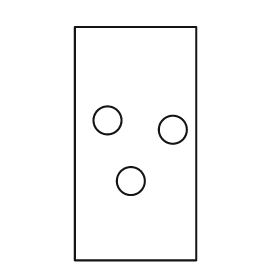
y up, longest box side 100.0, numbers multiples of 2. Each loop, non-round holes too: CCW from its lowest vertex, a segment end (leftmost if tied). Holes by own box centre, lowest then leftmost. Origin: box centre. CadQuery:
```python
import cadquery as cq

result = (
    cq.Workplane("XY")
    .moveTo(-26.0, -50.0)
    .lineTo(26.0, -50.0)
    .lineTo(26.0, 50.0)
    .lineTo(-26.0, 50.0)
    .close()
    .moveTo(-2.0, -16.0)
    .circle(6.0)
    .moveTo(16.0, 6.0)
    .circle(6.0)
    .moveTo(-12.0, 10.0)
    .circle(6.0)
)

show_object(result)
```